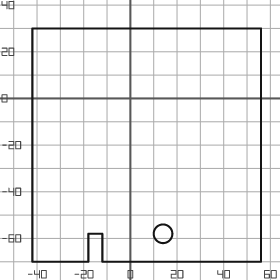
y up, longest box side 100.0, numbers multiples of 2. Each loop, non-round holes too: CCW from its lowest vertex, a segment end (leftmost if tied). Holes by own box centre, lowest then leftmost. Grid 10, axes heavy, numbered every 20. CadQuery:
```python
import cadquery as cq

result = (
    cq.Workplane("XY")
    .moveTo(-42.0, -70.0)
    .lineTo(-18.0, -70.0)
    .lineTo(-18.0, -58.0)
    .lineTo(-12.0, -58.0)
    .lineTo(-12.0, -70.0)
    .lineTo(56.0, -70.0)
    .lineTo(56.0, 30.0)
    .lineTo(-42.0, 30.0)
    .close()
    .moveTo(14.0, -58.0)
    .circle(4.0)
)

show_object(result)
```